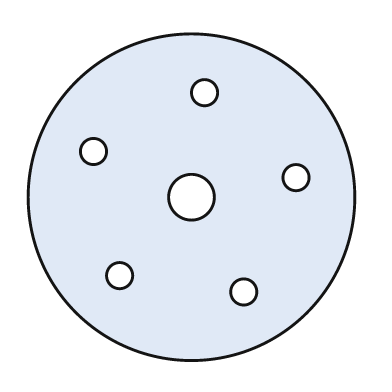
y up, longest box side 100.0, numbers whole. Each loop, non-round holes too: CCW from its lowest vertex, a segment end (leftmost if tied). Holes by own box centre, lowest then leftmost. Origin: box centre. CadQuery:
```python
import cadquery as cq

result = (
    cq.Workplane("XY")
    .moveTo(0.0, 0.0)
    .circle(50.0)
    .moveTo(16.0, -29.0)
    .circle(4.0)
    .moveTo(-22.0, -24.0)
    .circle(4.0)
    .moveTo(0.0, 0.0)
    .circle(7.0)
    .moveTo(32.0, 6.0)
    .circle(4.0)
    .moveTo(-30.0, 14.0)
    .circle(4.0)
    .moveTo(4.0, 32.0)
    .circle(4.0)
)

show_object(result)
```